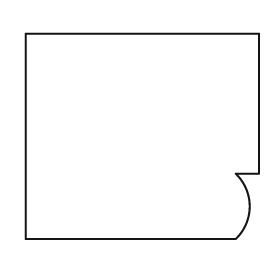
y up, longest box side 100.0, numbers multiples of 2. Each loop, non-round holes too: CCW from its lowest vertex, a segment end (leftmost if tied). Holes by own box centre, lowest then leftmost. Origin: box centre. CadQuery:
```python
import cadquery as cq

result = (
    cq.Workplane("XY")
    .moveTo(-50.0, -44.0)
    .lineTo(40.0, -44.0)
    .threePointArc((46.0, -30.0), (40.0, -16.0))
    .lineTo(50.0, -16.0)
    .lineTo(50.0, 44.0)
    .lineTo(-50.0, 44.0)
    .close()
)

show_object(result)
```